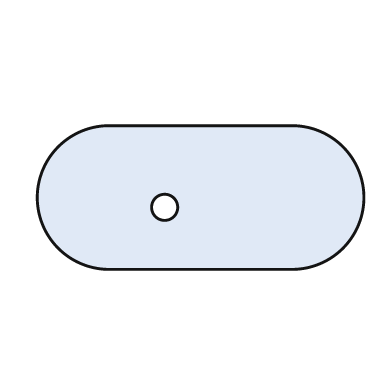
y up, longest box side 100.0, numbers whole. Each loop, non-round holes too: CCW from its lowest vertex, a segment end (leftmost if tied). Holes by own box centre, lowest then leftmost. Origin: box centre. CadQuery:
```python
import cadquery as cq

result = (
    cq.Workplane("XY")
    .moveTo(-28.0, -22.0)
    .lineTo(28.0, -22.0)
    .threePointArc((50.0, 0.0), (28.0, 22.0))
    .lineTo(-28.0, 22.0)
    .threePointArc((-50.0, 0.0), (-28.0, -22.0))
    .close()
    .moveTo(-11.0, -3.0)
    .circle(4.0)
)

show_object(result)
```